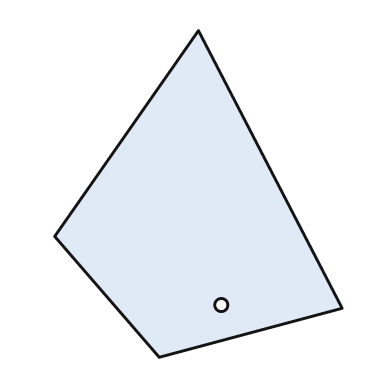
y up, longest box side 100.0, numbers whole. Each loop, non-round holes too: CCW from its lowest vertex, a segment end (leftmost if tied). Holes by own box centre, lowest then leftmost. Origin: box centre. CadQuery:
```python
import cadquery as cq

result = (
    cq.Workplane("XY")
    .moveTo(-12.0, -50.0)
    .lineTo(44.0, -35.0)
    .lineTo(0.0, 50.0)
    .lineTo(-44.0, -13.0)
    .close()
    .moveTo(7.0, -34.0)
    .circle(2.0)
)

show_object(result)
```